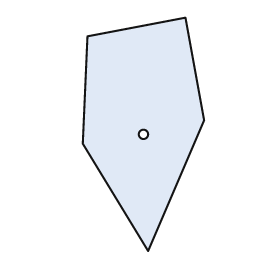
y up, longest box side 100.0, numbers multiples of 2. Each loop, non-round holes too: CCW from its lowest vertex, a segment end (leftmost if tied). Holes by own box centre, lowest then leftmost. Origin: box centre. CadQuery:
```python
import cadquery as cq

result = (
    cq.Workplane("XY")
    .moveTo(2.0, -50.0)
    .lineTo(26.0, 6.0)
    .lineTo(18.0, 50.0)
    .lineTo(-24.0, 42.0)
    .lineTo(-26.0, -4.0)
    .close()
    .moveTo(0.0, 0.0)
    .circle(2.0)
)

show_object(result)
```